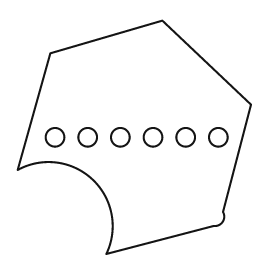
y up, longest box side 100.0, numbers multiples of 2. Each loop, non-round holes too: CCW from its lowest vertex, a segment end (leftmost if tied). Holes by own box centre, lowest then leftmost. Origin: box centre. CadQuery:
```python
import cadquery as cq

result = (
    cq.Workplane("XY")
    .moveTo(-12.0, -50.0)
    .lineTo(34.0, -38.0)
    .threePointArc((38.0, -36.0), (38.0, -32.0))
    .lineTo(50.0, 14.0)
    .lineTo(12.0, 50.0)
    .lineTo(-36.0, 36.0)
    .lineTo(-50.0, -14.0)
    .threePointArc((-18.0, -18.0), (-12.0, -50.0))
    .close()
    .moveTo(-34.0, 0.0)
    .circle(4.0)
    .moveTo(-20.0, 0.0)
    .circle(4.0)
    .moveTo(-6.0, 0.0)
    .circle(4.0)
    .moveTo(8.0, 0.0)
    .circle(4.0)
    .moveTo(22.0, 0.0)
    .circle(4.0)
    .moveTo(36.0, 0.0)
    .circle(4.0)
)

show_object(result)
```